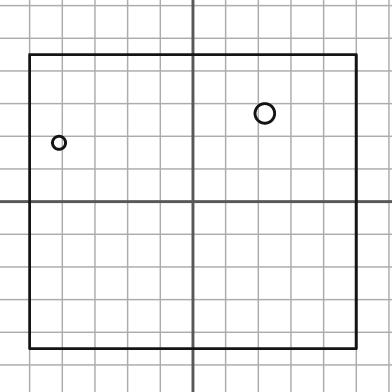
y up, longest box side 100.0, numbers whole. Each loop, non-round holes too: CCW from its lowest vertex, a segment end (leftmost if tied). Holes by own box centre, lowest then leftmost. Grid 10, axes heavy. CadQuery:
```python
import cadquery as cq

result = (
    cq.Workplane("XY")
    .moveTo(-50.0, -45.0)
    .lineTo(50.0, -45.0)
    .lineTo(50.0, 45.0)
    .lineTo(-50.0, 45.0)
    .close()
    .moveTo(-41.0, 18.0)
    .circle(2.0)
    .moveTo(22.0, 27.0)
    .circle(3.0)
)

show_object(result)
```